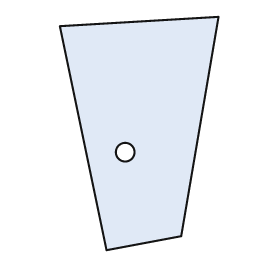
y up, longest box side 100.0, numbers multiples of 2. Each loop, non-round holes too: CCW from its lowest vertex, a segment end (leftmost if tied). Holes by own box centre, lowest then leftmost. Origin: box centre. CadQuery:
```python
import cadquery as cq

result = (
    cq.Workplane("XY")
    .moveTo(-14.0, -50.0)
    .lineTo(18.0, -44.0)
    .lineTo(34.0, 50.0)
    .lineTo(-34.0, 46.0)
    .close()
    .moveTo(-6.0, -8.0)
    .circle(4.0)
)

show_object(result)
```